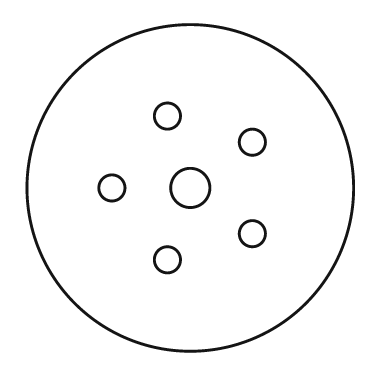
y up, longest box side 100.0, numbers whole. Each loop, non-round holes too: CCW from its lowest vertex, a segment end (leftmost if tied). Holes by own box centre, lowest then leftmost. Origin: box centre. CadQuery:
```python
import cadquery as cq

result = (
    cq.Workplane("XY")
    .moveTo(0.0, 0.0)
    .circle(50.0)
    .moveTo(-7.0, -22.0)
    .circle(4.0)
    .moveTo(19.0, -14.0)
    .circle(4.0)
    .moveTo(-24.0, 0.0)
    .circle(4.0)
    .moveTo(0.0, 0.0)
    .circle(6.0)
    .moveTo(19.0, 14.0)
    .circle(4.0)
    .moveTo(-7.0, 22.0)
    .circle(4.0)
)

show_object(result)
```